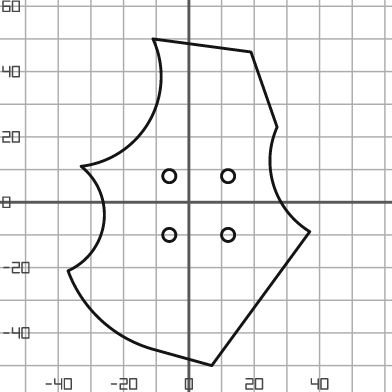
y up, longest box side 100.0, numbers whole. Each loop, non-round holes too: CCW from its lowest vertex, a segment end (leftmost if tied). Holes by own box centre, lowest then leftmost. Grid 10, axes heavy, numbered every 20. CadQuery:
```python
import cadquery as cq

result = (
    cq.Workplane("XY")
    .moveTo(7.0, -50.0)
    .lineTo(37.0, -9.0)
    .threePointArc((26.0, 5.0), (27.0, 23.0))
    .lineTo(19.0, 46.0)
    .lineTo(-11.0, 50.0)
    .threePointArc((-12.0, 25.0), (-33.0, 11.0))
    .threePointArc((-26.0, -6.0), (-37.0, -21.0))
    .threePointArc((-27.0, -36.0), (-11.0, -45.0))
    .close()
    .moveTo(-6.0, -10.0)
    .circle(2.0)
    .moveTo(12.0, -10.0)
    .circle(2.0)
    .moveTo(-6.0, 8.0)
    .circle(2.0)
    .moveTo(12.0, 8.0)
    .circle(2.0)
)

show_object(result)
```